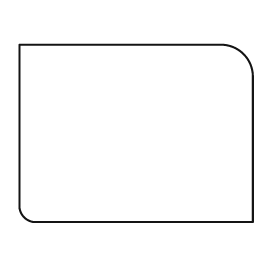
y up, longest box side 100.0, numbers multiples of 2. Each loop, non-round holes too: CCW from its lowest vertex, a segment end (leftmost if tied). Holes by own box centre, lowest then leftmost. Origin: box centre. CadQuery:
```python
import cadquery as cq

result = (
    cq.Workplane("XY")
    .moveTo(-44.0, -38.0)
    .lineTo(50.0, -38.0)
    .lineTo(50.0, 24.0)
    .threePointArc((46.0, 34.0), (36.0, 38.0))
    .lineTo(-50.0, 38.0)
    .lineTo(-50.0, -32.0)
    .threePointArc((-48.0, -36.0), (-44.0, -38.0))
    .close()
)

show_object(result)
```